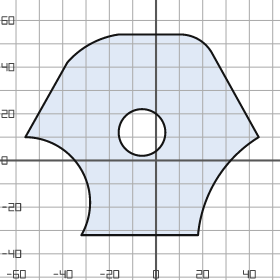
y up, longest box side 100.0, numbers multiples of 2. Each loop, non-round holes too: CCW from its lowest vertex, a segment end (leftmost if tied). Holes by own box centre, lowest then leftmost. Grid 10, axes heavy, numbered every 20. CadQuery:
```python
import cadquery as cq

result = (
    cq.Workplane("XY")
    .moveTo(-32.0, -32.0)
    .lineTo(18.0, -32.0)
    .threePointArc((26.0, -8.0), (44.0, 10.0))
    .lineTo(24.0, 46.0)
    .threePointArc((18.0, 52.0), (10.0, 54.0))
    .lineTo(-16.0, 54.0)
    .threePointArc((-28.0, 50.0), (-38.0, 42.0))
    .lineTo(-56.0, 10.0)
    .threePointArc((-32.0, -4.0), (-32.0, -32.0))
    .close()
    .moveTo(-6.0, 12.0)
    .circle(10.0)
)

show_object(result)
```